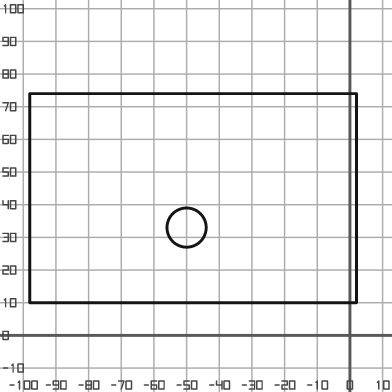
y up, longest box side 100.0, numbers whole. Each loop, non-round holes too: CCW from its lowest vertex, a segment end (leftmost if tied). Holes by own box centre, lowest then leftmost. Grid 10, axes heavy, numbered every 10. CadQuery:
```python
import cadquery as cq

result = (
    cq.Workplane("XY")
    .moveTo(-98.0, 10.0)
    .lineTo(2.0, 10.0)
    .lineTo(2.0, 74.0)
    .lineTo(-98.0, 74.0)
    .close()
    .moveTo(-50.0, 33.0)
    .circle(6.0)
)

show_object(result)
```